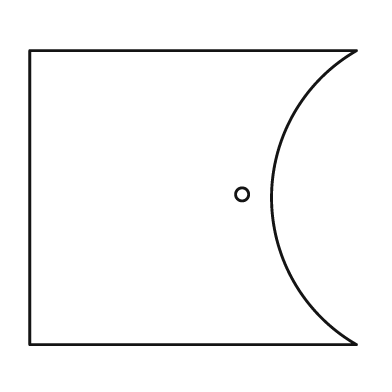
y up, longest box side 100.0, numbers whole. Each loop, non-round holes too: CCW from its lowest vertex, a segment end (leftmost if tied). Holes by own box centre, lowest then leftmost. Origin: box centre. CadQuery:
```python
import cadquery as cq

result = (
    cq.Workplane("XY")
    .moveTo(-50.0, -45.0)
    .lineTo(50.0, -45.0)
    .threePointArc((24.0, 0.0), (50.0, 45.0))
    .lineTo(-50.0, 45.0)
    .close()
    .moveTo(15.0, 1.0)
    .circle(2.0)
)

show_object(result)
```